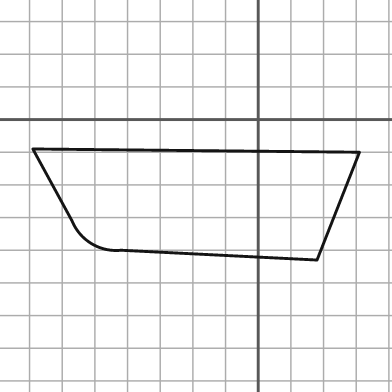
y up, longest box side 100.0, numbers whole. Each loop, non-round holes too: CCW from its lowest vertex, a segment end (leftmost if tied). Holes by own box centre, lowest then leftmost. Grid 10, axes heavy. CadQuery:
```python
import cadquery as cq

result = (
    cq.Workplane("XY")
    .moveTo(18.0, -43.0)
    .lineTo(31.0, -10.0)
    .lineTo(-69.0, -9.0)
    .lineTo(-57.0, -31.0)
    .threePointArc((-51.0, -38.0), (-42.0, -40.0))
    .close()
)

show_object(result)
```